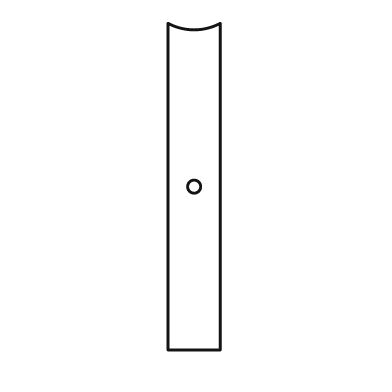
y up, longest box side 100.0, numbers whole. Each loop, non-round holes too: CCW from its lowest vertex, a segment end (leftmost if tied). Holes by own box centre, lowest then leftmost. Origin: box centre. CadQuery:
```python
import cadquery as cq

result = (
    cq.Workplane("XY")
    .moveTo(-8.0, -50.0)
    .lineTo(8.0, -50.0)
    .lineTo(8.0, 50.0)
    .threePointArc((0.0, 48.0), (-8.0, 50.0))
    .close()
    .moveTo(0.0, 0.0)
    .circle(2.0)
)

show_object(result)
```